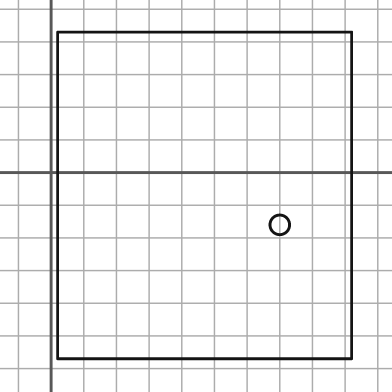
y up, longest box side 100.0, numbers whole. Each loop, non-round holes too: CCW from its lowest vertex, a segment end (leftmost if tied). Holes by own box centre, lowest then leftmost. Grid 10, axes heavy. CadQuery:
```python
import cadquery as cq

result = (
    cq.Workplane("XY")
    .moveTo(2.0, -57.0)
    .lineTo(92.0, -57.0)
    .lineTo(92.0, 43.0)
    .lineTo(2.0, 43.0)
    .close()
    .moveTo(70.0, -16.0)
    .circle(3.0)
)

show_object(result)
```